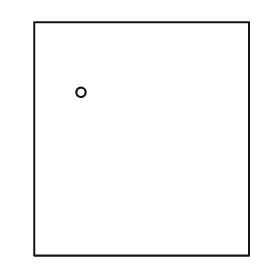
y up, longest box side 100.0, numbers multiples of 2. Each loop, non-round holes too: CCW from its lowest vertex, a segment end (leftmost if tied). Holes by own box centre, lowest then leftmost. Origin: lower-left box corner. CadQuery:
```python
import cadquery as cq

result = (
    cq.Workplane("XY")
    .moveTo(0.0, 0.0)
    .lineTo(92.0, 0.0)
    .lineTo(92.0, 100.0)
    .lineTo(0.0, 100.0)
    .close()
    .moveTo(20.0, 70.0)
    .circle(2.0)
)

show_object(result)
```